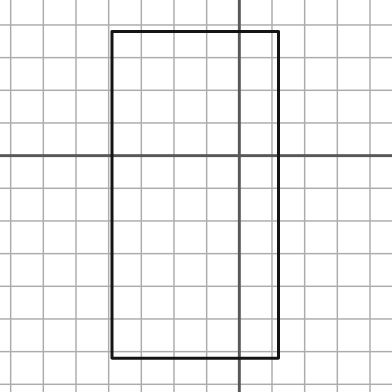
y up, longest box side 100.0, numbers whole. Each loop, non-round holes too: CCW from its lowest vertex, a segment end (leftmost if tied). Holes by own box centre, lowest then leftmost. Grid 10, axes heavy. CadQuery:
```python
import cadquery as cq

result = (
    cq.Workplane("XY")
    .moveTo(-39.0, -62.0)
    .lineTo(12.0, -62.0)
    .lineTo(12.0, 38.0)
    .lineTo(-39.0, 38.0)
    .close()
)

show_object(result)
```